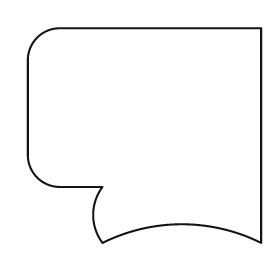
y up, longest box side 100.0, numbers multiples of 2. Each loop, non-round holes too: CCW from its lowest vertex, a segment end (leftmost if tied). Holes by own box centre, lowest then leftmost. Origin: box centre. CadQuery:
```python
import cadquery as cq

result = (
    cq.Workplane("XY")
    .moveTo(-18.0, -46.0)
    .threePointArc((16.0, -38.0), (50.0, -46.0))
    .lineTo(50.0, 46.0)
    .lineTo(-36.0, 46.0)
    .threePointArc((-46.0, 42.0), (-50.0, 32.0))
    .lineTo(-50.0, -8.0)
    .threePointArc((-46.0, -18.0), (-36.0, -22.0))
    .lineTo(-18.0, -22.0)
    .threePointArc((-22.0, -34.0), (-18.0, -46.0))
    .close()
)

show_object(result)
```